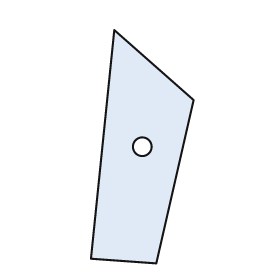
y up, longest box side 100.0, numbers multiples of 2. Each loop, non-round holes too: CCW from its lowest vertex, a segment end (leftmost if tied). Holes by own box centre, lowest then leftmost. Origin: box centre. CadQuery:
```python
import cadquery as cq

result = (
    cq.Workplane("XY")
    .moveTo(6.0, -50.0)
    .lineTo(22.0, 20.0)
    .lineTo(-12.0, 50.0)
    .lineTo(-22.0, -48.0)
    .close()
    .moveTo(0.0, 0.0)
    .circle(4.0)
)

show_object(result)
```